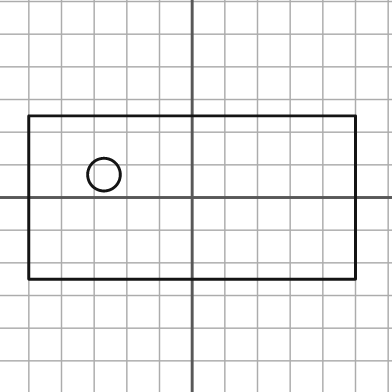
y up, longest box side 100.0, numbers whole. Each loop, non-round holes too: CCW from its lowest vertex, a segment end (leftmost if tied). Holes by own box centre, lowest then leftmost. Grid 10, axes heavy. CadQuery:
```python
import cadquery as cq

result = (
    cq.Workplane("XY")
    .moveTo(-50.0, -25.0)
    .lineTo(50.0, -25.0)
    .lineTo(50.0, 25.0)
    .lineTo(-50.0, 25.0)
    .close()
    .moveTo(-27.0, 7.0)
    .circle(5.0)
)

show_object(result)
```